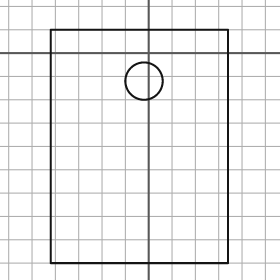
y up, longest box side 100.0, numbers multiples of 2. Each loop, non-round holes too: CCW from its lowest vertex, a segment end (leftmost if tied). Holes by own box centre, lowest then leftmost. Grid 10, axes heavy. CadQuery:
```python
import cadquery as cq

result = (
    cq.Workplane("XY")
    .moveTo(-42.0, -90.0)
    .lineTo(34.0, -90.0)
    .lineTo(34.0, 10.0)
    .lineTo(-42.0, 10.0)
    .close()
    .moveTo(-2.0, -12.0)
    .circle(8.0)
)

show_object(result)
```